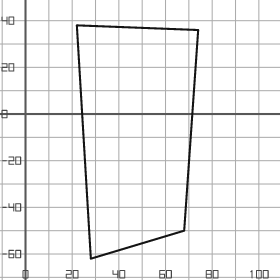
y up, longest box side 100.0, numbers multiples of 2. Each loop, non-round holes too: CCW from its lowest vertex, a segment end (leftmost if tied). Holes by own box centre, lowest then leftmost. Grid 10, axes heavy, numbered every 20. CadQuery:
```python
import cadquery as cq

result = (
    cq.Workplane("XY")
    .moveTo(28.0, -62.0)
    .lineTo(68.0, -50.0)
    .lineTo(74.0, 36.0)
    .lineTo(22.0, 38.0)
    .close()
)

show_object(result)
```